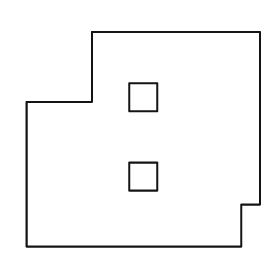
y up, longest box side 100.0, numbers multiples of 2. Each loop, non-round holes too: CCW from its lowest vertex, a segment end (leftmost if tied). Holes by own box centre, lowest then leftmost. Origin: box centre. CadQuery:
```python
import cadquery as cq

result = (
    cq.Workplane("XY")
    .moveTo(-50.0, -46.0)
    .lineTo(42.0, -46.0)
    .lineTo(42.0, -28.0)
    .lineTo(50.0, -28.0)
    .lineTo(50.0, 46.0)
    .lineTo(-22.0, 46.0)
    .lineTo(-22.0, 16.0)
    .lineTo(-50.0, 16.0)
    .close()
    .moveTo(-6.0, -22.0)
    .lineTo(6.0, -22.0)
    .lineTo(6.0, -10.0)
    .lineTo(-6.0, -10.0)
    .close()
    .moveTo(-6.0, 12.0)
    .lineTo(6.0, 12.0)
    .lineTo(6.0, 24.0)
    .lineTo(-6.0, 24.0)
    .close()
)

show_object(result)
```